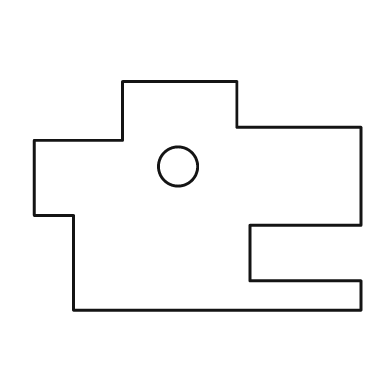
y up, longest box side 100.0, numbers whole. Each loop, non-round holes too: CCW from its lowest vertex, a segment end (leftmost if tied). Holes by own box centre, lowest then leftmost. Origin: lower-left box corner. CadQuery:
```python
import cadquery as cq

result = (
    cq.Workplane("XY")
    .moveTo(12.0, 0.0)
    .lineTo(100.0, 0.0)
    .lineTo(100.0, 9.0)
    .lineTo(66.0, 9.0)
    .lineTo(66.0, 26.0)
    .lineTo(100.0, 26.0)
    .lineTo(100.0, 56.0)
    .lineTo(62.0, 56.0)
    .lineTo(62.0, 70.0)
    .lineTo(27.0, 70.0)
    .lineTo(27.0, 52.0)
    .lineTo(0.0, 52.0)
    .lineTo(0.0, 29.0)
    .lineTo(12.0, 29.0)
    .close()
    .moveTo(44.0, 44.0)
    .circle(6.0)
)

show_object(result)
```